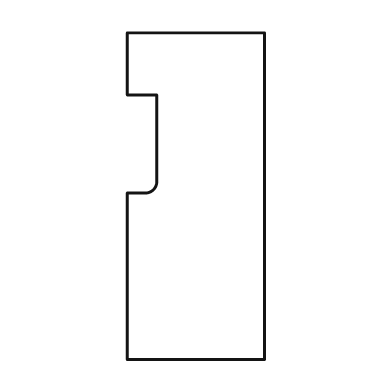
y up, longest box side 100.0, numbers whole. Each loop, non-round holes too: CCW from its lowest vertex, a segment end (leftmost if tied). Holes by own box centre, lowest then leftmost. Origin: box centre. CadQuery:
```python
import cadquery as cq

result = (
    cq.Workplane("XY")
    .moveTo(-21.0, -50.0)
    .lineTo(21.0, -50.0)
    .lineTo(21.0, 50.0)
    .lineTo(-21.0, 50.0)
    .lineTo(-21.0, 31.0)
    .lineTo(-12.0, 31.0)
    .lineTo(-12.0, 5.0)
    .threePointArc((-13.0, 2.0), (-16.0, 1.0))
    .lineTo(-21.0, 1.0)
    .close()
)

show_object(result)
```